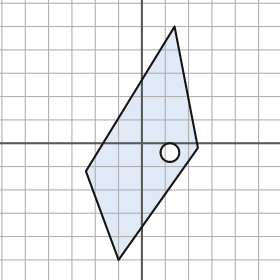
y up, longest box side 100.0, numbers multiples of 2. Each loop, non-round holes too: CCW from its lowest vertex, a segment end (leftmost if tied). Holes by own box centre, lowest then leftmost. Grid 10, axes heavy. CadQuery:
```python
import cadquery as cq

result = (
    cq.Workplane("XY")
    .moveTo(-10.0, -50.0)
    .lineTo(24.0, -2.0)
    .lineTo(14.0, 50.0)
    .lineTo(-24.0, -12.0)
    .close()
    .moveTo(12.0, -4.0)
    .circle(4.0)
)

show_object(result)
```